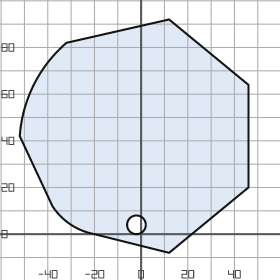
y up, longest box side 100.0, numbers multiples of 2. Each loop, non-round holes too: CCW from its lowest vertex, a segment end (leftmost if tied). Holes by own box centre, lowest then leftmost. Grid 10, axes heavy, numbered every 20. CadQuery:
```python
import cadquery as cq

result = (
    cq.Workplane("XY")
    .moveTo(12.0, -8.0)
    .lineTo(46.0, 20.0)
    .lineTo(46.0, 64.0)
    .lineTo(12.0, 92.0)
    .lineTo(-32.0, 82.0)
    .threePointArc((-46.0, 64.0), (-52.0, 42.0))
    .lineTo(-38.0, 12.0)
    .threePointArc((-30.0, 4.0), (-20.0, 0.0))
    .close()
    .moveTo(-2.0, 4.0)
    .circle(4.0)
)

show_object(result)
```